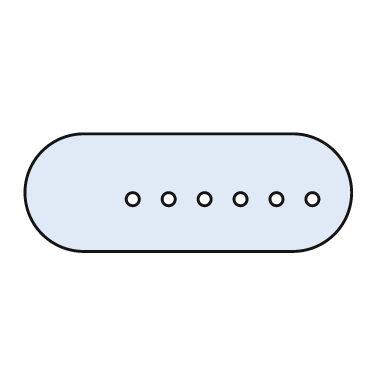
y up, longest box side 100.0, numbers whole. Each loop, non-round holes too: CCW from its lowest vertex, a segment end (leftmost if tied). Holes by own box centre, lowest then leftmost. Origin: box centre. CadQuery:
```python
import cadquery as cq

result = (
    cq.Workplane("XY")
    .moveTo(-32.0, -18.0)
    .lineTo(32.0, -18.0)
    .threePointArc((50.0, 0.0), (32.0, 18.0))
    .lineTo(-32.0, 18.0)
    .threePointArc((-50.0, 0.0), (-32.0, -18.0))
    .close()
    .moveTo(-17.0, -2.0)
    .circle(2.0)
    .moveTo(-6.0, -2.0)
    .circle(2.0)
    .moveTo(5.0, -2.0)
    .circle(2.0)
    .moveTo(16.0, -2.0)
    .circle(2.0)
    .moveTo(27.0, -2.0)
    .circle(2.0)
    .moveTo(38.0, -2.0)
    .circle(2.0)
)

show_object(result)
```